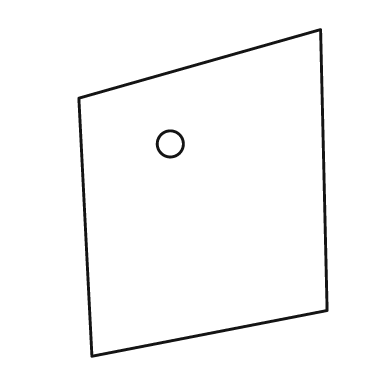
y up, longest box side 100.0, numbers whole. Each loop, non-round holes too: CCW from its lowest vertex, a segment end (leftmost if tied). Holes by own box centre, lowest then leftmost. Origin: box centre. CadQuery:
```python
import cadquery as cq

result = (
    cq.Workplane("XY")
    .moveTo(-34.0, -50.0)
    .lineTo(38.0, -36.0)
    .lineTo(36.0, 50.0)
    .lineTo(-38.0, 29.0)
    .close()
    .moveTo(-10.0, 15.0)
    .circle(4.0)
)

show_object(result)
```